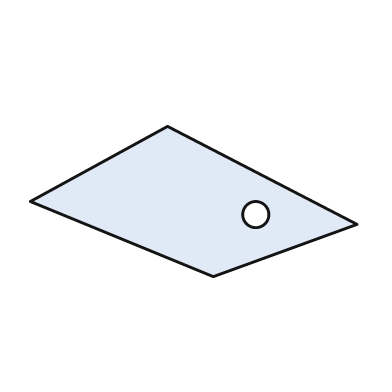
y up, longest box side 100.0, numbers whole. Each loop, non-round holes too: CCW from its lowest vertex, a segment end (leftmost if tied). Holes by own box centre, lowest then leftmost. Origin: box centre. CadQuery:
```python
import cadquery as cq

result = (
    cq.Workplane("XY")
    .moveTo(6.0, -23.0)
    .lineTo(50.0, -7.0)
    .lineTo(-8.0, 23.0)
    .lineTo(-50.0, 0.0)
    .close()
    .moveTo(19.0, -4.0)
    .circle(4.0)
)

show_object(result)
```